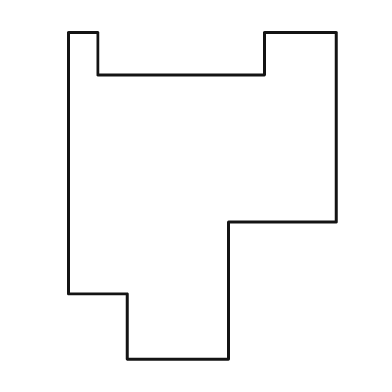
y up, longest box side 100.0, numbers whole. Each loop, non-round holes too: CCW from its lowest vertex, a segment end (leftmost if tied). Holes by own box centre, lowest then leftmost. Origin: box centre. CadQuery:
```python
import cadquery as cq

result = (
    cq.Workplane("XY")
    .moveTo(-23.0, -50.0)
    .lineTo(8.0, -50.0)
    .lineTo(8.0, -8.0)
    .lineTo(41.0, -8.0)
    .lineTo(41.0, 50.0)
    .lineTo(19.0, 50.0)
    .lineTo(19.0, 37.0)
    .lineTo(-32.0, 37.0)
    .lineTo(-32.0, 50.0)
    .lineTo(-41.0, 50.0)
    .lineTo(-41.0, -30.0)
    .lineTo(-23.0, -30.0)
    .close()
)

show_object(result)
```